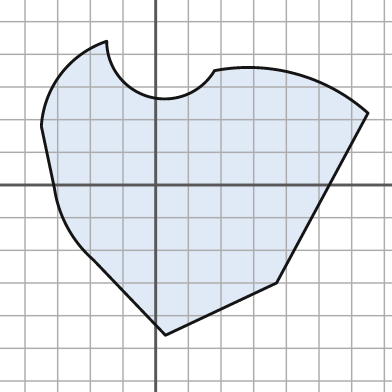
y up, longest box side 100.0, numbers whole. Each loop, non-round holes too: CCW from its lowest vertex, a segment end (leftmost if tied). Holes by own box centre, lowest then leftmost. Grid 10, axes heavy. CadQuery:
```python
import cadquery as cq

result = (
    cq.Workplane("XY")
    .moveTo(3.0, -46.0)
    .lineTo(37.0, -30.0)
    .lineTo(65.0, 22.0)
    .threePointArc((43.0, 34.0), (18.0, 35.0))
    .threePointArc((-2.0, 27.0), (-15.0, 44.0))
    .threePointArc((-29.0, 34.0), (-35.0, 18.0))
    .lineTo(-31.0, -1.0)
    .threePointArc((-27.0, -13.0), (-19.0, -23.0))
    .close()
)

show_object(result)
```